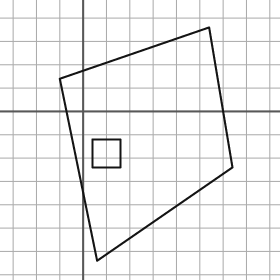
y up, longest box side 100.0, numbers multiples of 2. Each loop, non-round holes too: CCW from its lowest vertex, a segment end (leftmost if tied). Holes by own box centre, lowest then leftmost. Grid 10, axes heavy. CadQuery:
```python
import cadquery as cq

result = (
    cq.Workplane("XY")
    .moveTo(6.0, -64.0)
    .lineTo(64.0, -24.0)
    .lineTo(54.0, 36.0)
    .lineTo(-10.0, 14.0)
    .close()
    .moveTo(4.0, -24.0)
    .lineTo(16.0, -24.0)
    .lineTo(16.0, -12.0)
    .lineTo(4.0, -12.0)
    .close()
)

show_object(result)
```